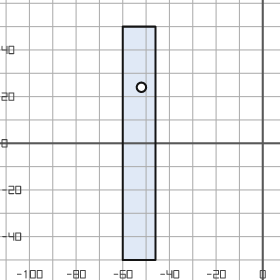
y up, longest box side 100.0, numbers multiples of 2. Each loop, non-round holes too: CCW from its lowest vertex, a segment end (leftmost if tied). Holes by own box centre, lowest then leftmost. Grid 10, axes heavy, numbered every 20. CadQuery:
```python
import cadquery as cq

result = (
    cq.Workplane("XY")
    .moveTo(-60.0, -50.0)
    .lineTo(-46.0, -50.0)
    .lineTo(-46.0, 50.0)
    .lineTo(-60.0, 50.0)
    .close()
    .moveTo(-52.0, 24.0)
    .circle(2.0)
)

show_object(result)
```